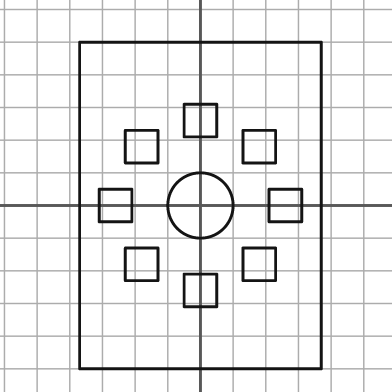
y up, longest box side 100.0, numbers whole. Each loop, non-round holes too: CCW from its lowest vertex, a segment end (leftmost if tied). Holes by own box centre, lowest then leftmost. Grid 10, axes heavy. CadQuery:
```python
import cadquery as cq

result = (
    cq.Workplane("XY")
    .moveTo(-37.0, -50.0)
    .lineTo(37.0, -50.0)
    .lineTo(37.0, 50.0)
    .lineTo(-37.0, 50.0)
    .close()
    .moveTo(-5.0, -31.0)
    .lineTo(5.0, -31.0)
    .lineTo(5.0, -21.0)
    .lineTo(-5.0, -21.0)
    .close()
    .moveTo(-23.0, -23.0)
    .lineTo(-13.0, -23.0)
    .lineTo(-13.0, -13.0)
    .lineTo(-23.0, -13.0)
    .close()
    .moveTo(13.0, -23.0)
    .lineTo(23.0, -23.0)
    .lineTo(23.0, -13.0)
    .lineTo(13.0, -13.0)
    .close()
    .moveTo(-31.0, -5.0)
    .lineTo(-21.0, -5.0)
    .lineTo(-21.0, 5.0)
    .lineTo(-31.0, 5.0)
    .close()
    .moveTo(0.0, 0.0)
    .circle(10.0)
    .moveTo(21.0, -5.0)
    .lineTo(31.0, -5.0)
    .lineTo(31.0, 5.0)
    .lineTo(21.0, 5.0)
    .close()
    .moveTo(-23.0, 13.0)
    .lineTo(-13.0, 13.0)
    .lineTo(-13.0, 23.0)
    .lineTo(-23.0, 23.0)
    .close()
    .moveTo(13.0, 13.0)
    .lineTo(23.0, 13.0)
    .lineTo(23.0, 23.0)
    .lineTo(13.0, 23.0)
    .close()
    .moveTo(-5.0, 21.0)
    .lineTo(5.0, 21.0)
    .lineTo(5.0, 31.0)
    .lineTo(-5.0, 31.0)
    .close()
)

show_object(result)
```